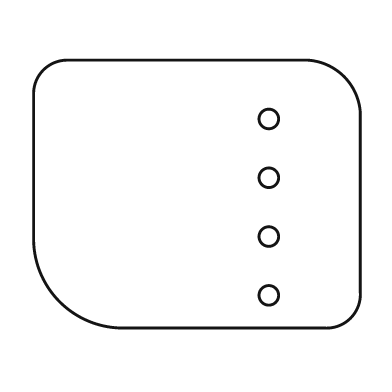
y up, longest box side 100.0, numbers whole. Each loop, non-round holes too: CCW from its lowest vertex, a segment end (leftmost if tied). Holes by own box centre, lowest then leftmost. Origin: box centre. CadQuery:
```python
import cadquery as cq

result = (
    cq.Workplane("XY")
    .moveTo(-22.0, -41.0)
    .lineTo(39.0, -41.0)
    .threePointArc((47.0, -38.0), (50.0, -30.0))
    .lineTo(50.0, 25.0)
    .threePointArc((45.0, 36.0), (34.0, 41.0))
    .lineTo(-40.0, 41.0)
    .threePointArc((-47.0, 38.0), (-50.0, 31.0))
    .lineTo(-50.0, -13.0)
    .threePointArc((-42.0, -33.0), (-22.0, -41.0))
    .close()
    .moveTo(22.0, -31.0)
    .circle(3.0)
    .moveTo(22.0, -13.0)
    .circle(3.0)
    .moveTo(22.0, 5.0)
    .circle(3.0)
    .moveTo(22.0, 23.0)
    .circle(3.0)
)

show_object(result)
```